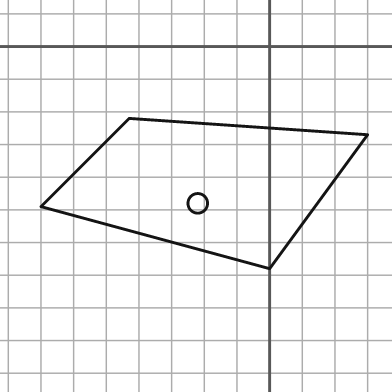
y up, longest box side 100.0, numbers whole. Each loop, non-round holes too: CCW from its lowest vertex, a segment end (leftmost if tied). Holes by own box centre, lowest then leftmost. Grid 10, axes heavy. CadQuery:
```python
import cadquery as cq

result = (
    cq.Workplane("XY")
    .moveTo(0.0, -68.0)
    .lineTo(30.0, -27.0)
    .lineTo(-43.0, -22.0)
    .lineTo(-70.0, -49.0)
    .close()
    .moveTo(-22.0, -48.0)
    .circle(3.0)
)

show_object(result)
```